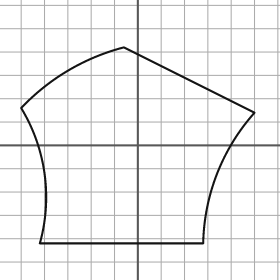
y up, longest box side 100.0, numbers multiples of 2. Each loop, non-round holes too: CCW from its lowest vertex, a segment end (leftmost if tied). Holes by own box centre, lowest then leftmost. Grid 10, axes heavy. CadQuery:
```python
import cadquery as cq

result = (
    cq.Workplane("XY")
    .moveTo(-42.0, -42.0)
    .lineTo(28.0, -42.0)
    .threePointArc((34.0, -12.0), (50.0, 14.0))
    .lineTo(-6.0, 42.0)
    .threePointArc((-30.0, 32.0), (-50.0, 16.0))
    .threePointArc((-40.0, -12.0), (-42.0, -42.0))
    .close()
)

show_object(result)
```